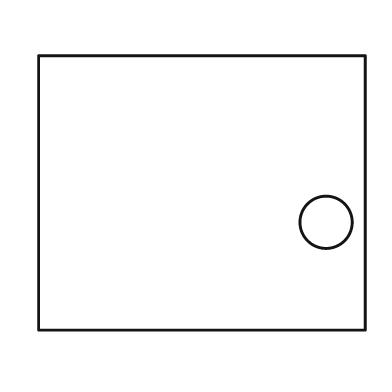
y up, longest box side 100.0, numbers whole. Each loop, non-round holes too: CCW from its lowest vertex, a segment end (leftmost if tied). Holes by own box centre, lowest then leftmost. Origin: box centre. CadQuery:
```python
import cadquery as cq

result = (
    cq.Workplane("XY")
    .moveTo(-50.0, -42.0)
    .lineTo(50.0, -42.0)
    .lineTo(50.0, 42.0)
    .lineTo(-50.0, 42.0)
    .close()
    .moveTo(38.0, -9.0)
    .circle(8.0)
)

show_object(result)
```